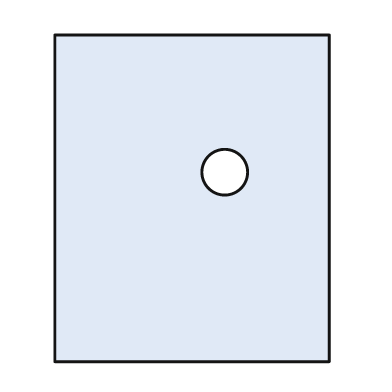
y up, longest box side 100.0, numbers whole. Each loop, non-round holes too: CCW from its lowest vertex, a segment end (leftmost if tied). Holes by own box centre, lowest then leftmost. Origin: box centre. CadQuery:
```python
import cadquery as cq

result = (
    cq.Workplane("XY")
    .moveTo(-42.0, -50.0)
    .lineTo(42.0, -50.0)
    .lineTo(42.0, 50.0)
    .lineTo(-42.0, 50.0)
    .close()
    .moveTo(10.0, 8.0)
    .circle(7.0)
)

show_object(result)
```